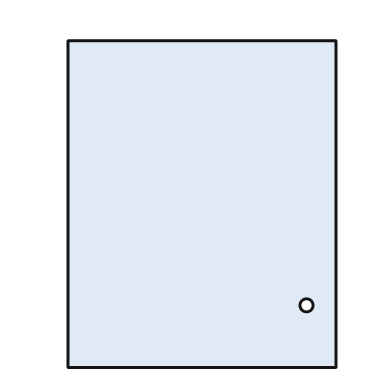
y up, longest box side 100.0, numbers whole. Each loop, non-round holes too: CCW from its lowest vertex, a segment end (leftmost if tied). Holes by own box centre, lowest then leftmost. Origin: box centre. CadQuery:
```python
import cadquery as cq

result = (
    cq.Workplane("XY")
    .moveTo(-41.0, -50.0)
    .lineTo(41.0, -50.0)
    .lineTo(41.0, 50.0)
    .lineTo(-41.0, 50.0)
    .close()
    .moveTo(32.0, -31.0)
    .circle(2.0)
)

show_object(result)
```